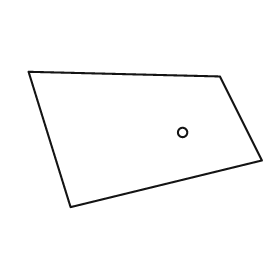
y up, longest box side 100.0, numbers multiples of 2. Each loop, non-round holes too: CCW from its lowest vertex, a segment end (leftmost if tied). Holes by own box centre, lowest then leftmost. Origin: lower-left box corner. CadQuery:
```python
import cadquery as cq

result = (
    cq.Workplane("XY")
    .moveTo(18.0, 0.0)
    .lineTo(100.0, 20.0)
    .lineTo(82.0, 56.0)
    .lineTo(0.0, 58.0)
    .close()
    .moveTo(66.0, 32.0)
    .circle(2.0)
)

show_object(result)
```